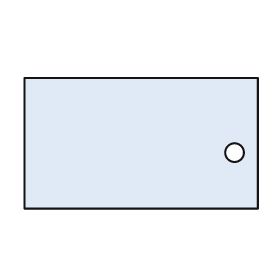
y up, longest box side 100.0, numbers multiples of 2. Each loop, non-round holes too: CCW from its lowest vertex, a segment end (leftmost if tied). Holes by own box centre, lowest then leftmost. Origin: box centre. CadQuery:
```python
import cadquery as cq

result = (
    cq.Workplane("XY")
    .moveTo(-50.0, -28.0)
    .lineTo(50.0, -28.0)
    .lineTo(50.0, 28.0)
    .lineTo(-50.0, 28.0)
    .close()
    .moveTo(40.0, -4.0)
    .circle(4.0)
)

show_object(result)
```